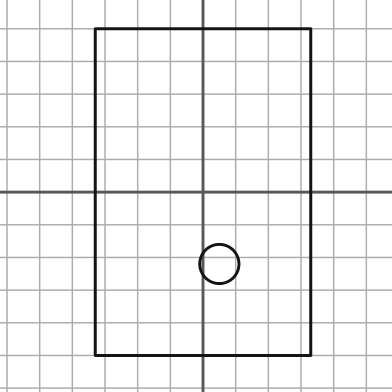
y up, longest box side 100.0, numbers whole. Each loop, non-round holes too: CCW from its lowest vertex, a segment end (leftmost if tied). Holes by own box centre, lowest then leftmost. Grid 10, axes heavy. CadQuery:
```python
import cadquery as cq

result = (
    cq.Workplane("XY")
    .moveTo(-33.0, -50.0)
    .lineTo(33.0, -50.0)
    .lineTo(33.0, 50.0)
    .lineTo(-33.0, 50.0)
    .close()
    .moveTo(5.0, -22.0)
    .circle(6.0)
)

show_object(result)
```